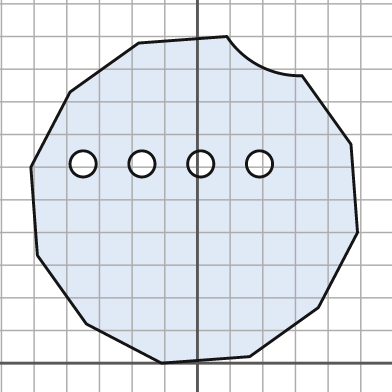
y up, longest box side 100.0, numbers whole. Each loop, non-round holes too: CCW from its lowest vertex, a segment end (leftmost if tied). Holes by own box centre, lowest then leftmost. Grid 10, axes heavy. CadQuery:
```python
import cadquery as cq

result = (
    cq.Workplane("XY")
    .moveTo(-11.0, 0.0)
    .lineTo(16.0, 2.0)
    .lineTo(37.0, 17.0)
    .lineTo(49.0, 40.0)
    .lineTo(47.0, 67.0)
    .lineTo(32.0, 88.0)
    .threePointArc((19.0, 91.0), (9.0, 100.0))
    .lineTo(-18.0, 98.0)
    .lineTo(-39.0, 83.0)
    .lineTo(-51.0, 60.0)
    .lineTo(-49.0, 33.0)
    .lineTo(-34.0, 12.0)
    .close()
    .moveTo(-35.0, 61.0)
    .circle(4.0)
    .moveTo(-17.0, 61.0)
    .circle(4.0)
    .moveTo(1.0, 61.0)
    .circle(4.0)
    .moveTo(19.0, 61.0)
    .circle(4.0)
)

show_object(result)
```